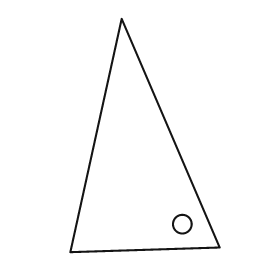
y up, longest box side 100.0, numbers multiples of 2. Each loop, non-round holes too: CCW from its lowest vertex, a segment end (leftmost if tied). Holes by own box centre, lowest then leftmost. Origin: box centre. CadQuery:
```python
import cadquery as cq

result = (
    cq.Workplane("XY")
    .moveTo(-32.0, -50.0)
    .lineTo(32.0, -48.0)
    .lineTo(-10.0, 50.0)
    .close()
    .moveTo(16.0, -38.0)
    .circle(4.0)
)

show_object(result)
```